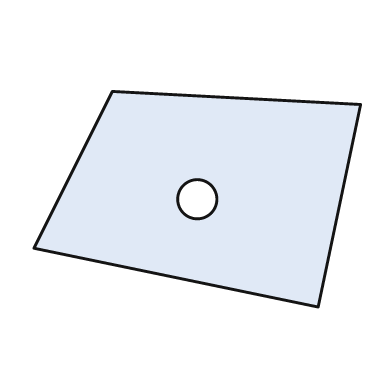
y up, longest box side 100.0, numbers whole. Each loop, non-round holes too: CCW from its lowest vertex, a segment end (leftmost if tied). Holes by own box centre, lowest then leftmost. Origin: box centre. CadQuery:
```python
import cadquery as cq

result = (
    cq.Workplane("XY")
    .moveTo(37.0, -33.0)
    .lineTo(50.0, 29.0)
    .lineTo(-26.0, 33.0)
    .lineTo(-50.0, -15.0)
    .close()
    .moveTo(0.0, 0.0)
    .circle(6.0)
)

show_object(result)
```